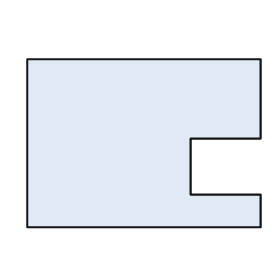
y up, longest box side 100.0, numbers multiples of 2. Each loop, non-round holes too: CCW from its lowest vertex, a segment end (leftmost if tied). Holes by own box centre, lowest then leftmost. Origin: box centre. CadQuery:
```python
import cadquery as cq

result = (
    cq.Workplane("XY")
    .moveTo(-50.0, -36.0)
    .lineTo(50.0, -36.0)
    .lineTo(50.0, -22.0)
    .lineTo(20.0, -22.0)
    .lineTo(20.0, 2.0)
    .lineTo(50.0, 2.0)
    .lineTo(50.0, 36.0)
    .lineTo(-50.0, 36.0)
    .close()
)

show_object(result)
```